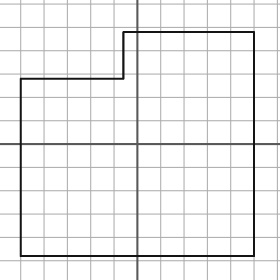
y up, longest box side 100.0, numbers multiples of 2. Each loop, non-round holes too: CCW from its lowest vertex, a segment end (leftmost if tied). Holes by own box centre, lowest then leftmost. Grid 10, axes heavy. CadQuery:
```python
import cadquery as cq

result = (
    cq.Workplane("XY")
    .moveTo(-50.0, -48.0)
    .lineTo(50.0, -48.0)
    .lineTo(50.0, 48.0)
    .lineTo(-6.0, 48.0)
    .lineTo(-6.0, 28.0)
    .lineTo(-50.0, 28.0)
    .close()
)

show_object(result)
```